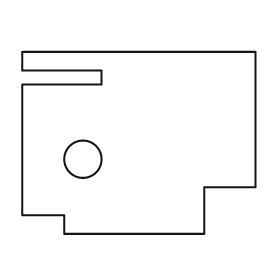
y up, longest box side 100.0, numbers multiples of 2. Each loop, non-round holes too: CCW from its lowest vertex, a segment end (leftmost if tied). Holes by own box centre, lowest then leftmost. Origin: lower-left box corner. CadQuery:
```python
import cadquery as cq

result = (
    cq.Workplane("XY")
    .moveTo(18.0, 0.0)
    .lineTo(78.0, 0.0)
    .lineTo(78.0, 20.0)
    .lineTo(100.0, 20.0)
    .lineTo(100.0, 78.0)
    .lineTo(0.0, 78.0)
    .lineTo(0.0, 70.0)
    .lineTo(34.0, 70.0)
    .lineTo(34.0, 64.0)
    .lineTo(0.0, 64.0)
    .lineTo(0.0, 8.0)
    .lineTo(18.0, 8.0)
    .close()
    .moveTo(26.0, 32.0)
    .circle(8.0)
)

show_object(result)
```